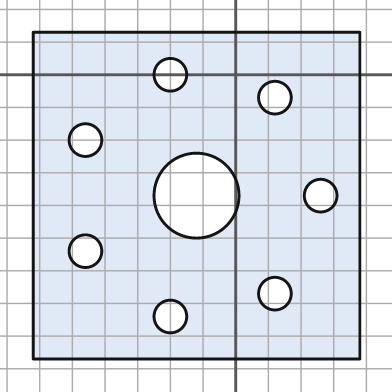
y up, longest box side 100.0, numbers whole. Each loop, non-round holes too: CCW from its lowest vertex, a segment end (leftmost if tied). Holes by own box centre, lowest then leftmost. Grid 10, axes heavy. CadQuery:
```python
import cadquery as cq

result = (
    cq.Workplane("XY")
    .moveTo(-62.0, -87.0)
    .lineTo(38.0, -87.0)
    .lineTo(38.0, 13.0)
    .lineTo(-62.0, 13.0)
    .close()
    .moveTo(-20.0, -74.0)
    .circle(5.0)
    .moveTo(12.0, -67.0)
    .circle(5.0)
    .moveTo(-46.0, -54.0)
    .circle(5.0)
    .moveTo(-12.0, -37.0)
    .circle(13.0)
    .moveTo(26.0, -37.0)
    .circle(5.0)
    .moveTo(-46.0, -20.0)
    .circle(5.0)
    .moveTo(12.0, -7.0)
    .circle(5.0)
    .moveTo(-20.0, 0.0)
    .circle(5.0)
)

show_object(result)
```